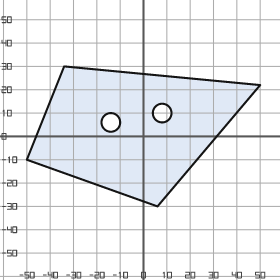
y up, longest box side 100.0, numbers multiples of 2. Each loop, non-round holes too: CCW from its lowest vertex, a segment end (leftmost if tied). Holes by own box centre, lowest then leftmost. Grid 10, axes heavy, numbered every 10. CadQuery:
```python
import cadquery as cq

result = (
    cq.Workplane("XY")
    .moveTo(6.0, -30.0)
    .lineTo(50.0, 22.0)
    .lineTo(-34.0, 30.0)
    .lineTo(-50.0, -10.0)
    .close()
    .moveTo(-14.0, 6.0)
    .circle(4.0)
    .moveTo(8.0, 10.0)
    .circle(4.0)
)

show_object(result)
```